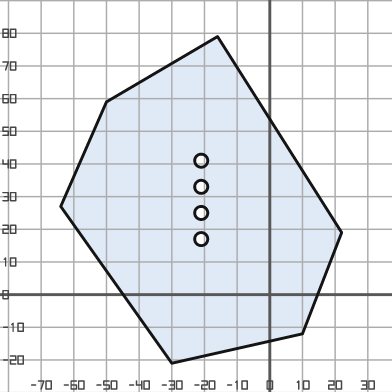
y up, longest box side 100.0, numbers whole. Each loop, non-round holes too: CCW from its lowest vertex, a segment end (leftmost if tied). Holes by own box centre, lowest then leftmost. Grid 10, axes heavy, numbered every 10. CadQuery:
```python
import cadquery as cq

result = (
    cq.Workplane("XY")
    .moveTo(-30.0, -21.0)
    .lineTo(10.0, -12.0)
    .lineTo(22.0, 19.0)
    .lineTo(-16.0, 79.0)
    .lineTo(-50.0, 59.0)
    .lineTo(-64.0, 27.0)
    .close()
    .moveTo(-21.0, 17.0)
    .circle(2.0)
    .moveTo(-21.0, 25.0)
    .circle(2.0)
    .moveTo(-21.0, 33.0)
    .circle(2.0)
    .moveTo(-21.0, 41.0)
    .circle(2.0)
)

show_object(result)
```